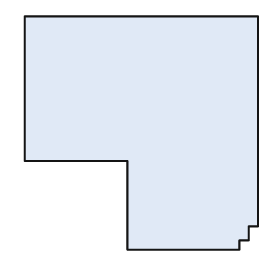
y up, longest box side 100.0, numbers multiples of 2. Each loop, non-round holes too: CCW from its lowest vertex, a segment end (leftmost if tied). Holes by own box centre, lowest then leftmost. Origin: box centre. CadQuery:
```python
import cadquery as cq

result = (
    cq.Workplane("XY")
    .moveTo(-6.0, -50.0)
    .lineTo(42.0, -50.0)
    .lineTo(42.0, -46.0)
    .lineTo(46.0, -46.0)
    .lineTo(46.0, -40.0)
    .lineTo(50.0, -40.0)
    .lineTo(50.0, 50.0)
    .lineTo(-50.0, 50.0)
    .lineTo(-50.0, -12.0)
    .lineTo(-6.0, -12.0)
    .close()
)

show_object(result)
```